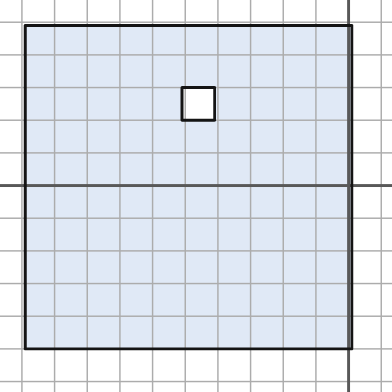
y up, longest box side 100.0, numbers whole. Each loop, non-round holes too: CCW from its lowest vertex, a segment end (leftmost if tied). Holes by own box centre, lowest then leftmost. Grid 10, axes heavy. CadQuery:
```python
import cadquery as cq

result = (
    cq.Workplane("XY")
    .moveTo(-99.0, -50.0)
    .lineTo(1.0, -50.0)
    .lineTo(1.0, 49.0)
    .lineTo(-99.0, 49.0)
    .close()
    .moveTo(-51.0, 20.0)
    .lineTo(-41.0, 20.0)
    .lineTo(-41.0, 30.0)
    .lineTo(-51.0, 30.0)
    .close()
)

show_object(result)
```